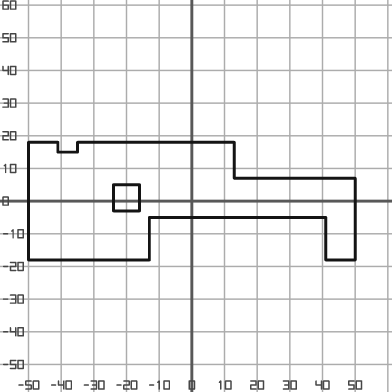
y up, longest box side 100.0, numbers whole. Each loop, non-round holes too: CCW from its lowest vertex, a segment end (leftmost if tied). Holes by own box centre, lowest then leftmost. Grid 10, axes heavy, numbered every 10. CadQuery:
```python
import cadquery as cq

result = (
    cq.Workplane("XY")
    .moveTo(-50.0, -18.0)
    .lineTo(-13.0, -18.0)
    .lineTo(-13.0, -5.0)
    .lineTo(41.0, -5.0)
    .lineTo(41.0, -18.0)
    .lineTo(50.0, -18.0)
    .lineTo(50.0, 7.0)
    .lineTo(13.0, 7.0)
    .lineTo(13.0, 18.0)
    .lineTo(-35.0, 18.0)
    .lineTo(-35.0, 15.0)
    .lineTo(-41.0, 15.0)
    .lineTo(-41.0, 18.0)
    .lineTo(-50.0, 18.0)
    .close()
    .moveTo(-24.0, -3.0)
    .lineTo(-16.0, -3.0)
    .lineTo(-16.0, 5.0)
    .lineTo(-24.0, 5.0)
    .close()
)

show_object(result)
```